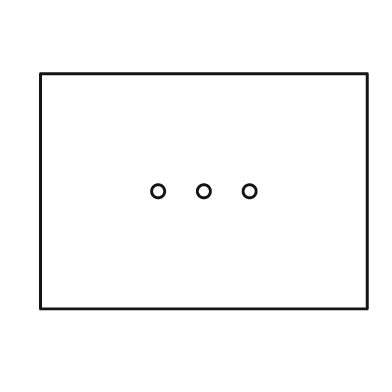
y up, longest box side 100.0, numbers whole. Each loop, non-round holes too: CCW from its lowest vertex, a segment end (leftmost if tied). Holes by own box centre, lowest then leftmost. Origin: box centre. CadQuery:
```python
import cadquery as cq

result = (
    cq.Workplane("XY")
    .moveTo(-50.0, -36.0)
    .lineTo(50.0, -36.0)
    .lineTo(50.0, 36.0)
    .lineTo(-50.0, 36.0)
    .close()
    .moveTo(-14.0, 0.0)
    .circle(2.0)
    .moveTo(0.0, 0.0)
    .circle(2.0)
    .moveTo(14.0, 0.0)
    .circle(2.0)
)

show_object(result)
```